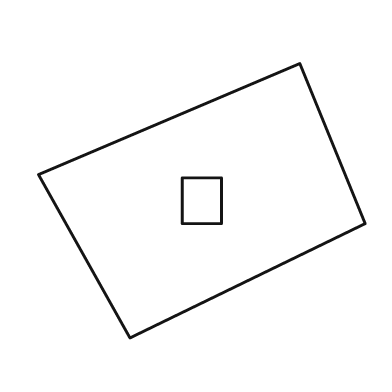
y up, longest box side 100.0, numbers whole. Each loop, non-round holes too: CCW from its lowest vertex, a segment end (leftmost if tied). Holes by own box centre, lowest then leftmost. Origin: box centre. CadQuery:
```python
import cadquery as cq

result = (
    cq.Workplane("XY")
    .moveTo(-22.0, -42.0)
    .lineTo(50.0, -7.0)
    .lineTo(30.0, 42.0)
    .lineTo(-50.0, 8.0)
    .close()
    .moveTo(-6.0, -7.0)
    .lineTo(6.0, -7.0)
    .lineTo(6.0, 7.0)
    .lineTo(-6.0, 7.0)
    .close()
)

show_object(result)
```